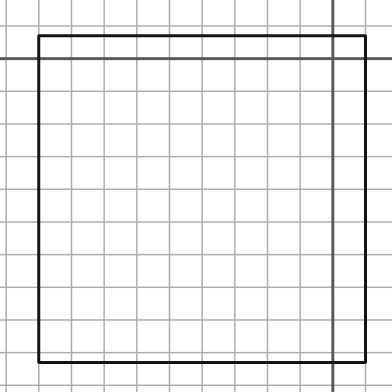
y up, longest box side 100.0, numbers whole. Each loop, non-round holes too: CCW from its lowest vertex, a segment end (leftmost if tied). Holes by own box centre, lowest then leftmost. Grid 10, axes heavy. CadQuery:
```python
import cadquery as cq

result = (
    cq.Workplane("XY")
    .moveTo(-90.0, -93.0)
    .lineTo(10.0, -93.0)
    .lineTo(10.0, 7.0)
    .lineTo(-90.0, 7.0)
    .close()
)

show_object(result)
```